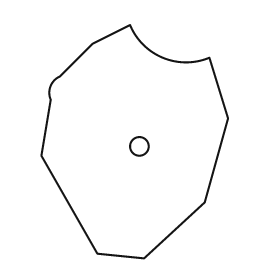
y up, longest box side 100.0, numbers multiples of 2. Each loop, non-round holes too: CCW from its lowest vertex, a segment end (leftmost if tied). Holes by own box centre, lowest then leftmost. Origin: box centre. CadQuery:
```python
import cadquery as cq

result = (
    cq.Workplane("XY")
    .moveTo(4.0, -50.0)
    .lineTo(30.0, -26.0)
    .lineTo(40.0, 10.0)
    .lineTo(32.0, 36.0)
    .threePointArc((12.0, 36.0), (-2.0, 50.0))
    .lineTo(-18.0, 42.0)
    .lineTo(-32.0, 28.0)
    .threePointArc((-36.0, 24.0), (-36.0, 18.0))
    .lineTo(-40.0, -6.0)
    .lineTo(-16.0, -48.0)
    .close()
    .moveTo(2.0, -2.0)
    .circle(4.0)
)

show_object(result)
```